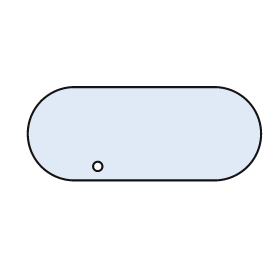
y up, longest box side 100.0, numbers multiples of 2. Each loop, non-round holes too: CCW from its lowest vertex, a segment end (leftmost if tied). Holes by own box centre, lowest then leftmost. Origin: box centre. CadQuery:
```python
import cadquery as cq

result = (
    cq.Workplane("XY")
    .moveTo(-30.0, -20.0)
    .lineTo(30.0, -20.0)
    .threePointArc((50.0, 0.0), (30.0, 20.0))
    .lineTo(-30.0, 20.0)
    .threePointArc((-50.0, 0.0), (-30.0, -20.0))
    .close()
    .moveTo(-20.0, -14.0)
    .circle(2.0)
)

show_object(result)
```